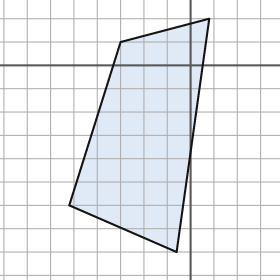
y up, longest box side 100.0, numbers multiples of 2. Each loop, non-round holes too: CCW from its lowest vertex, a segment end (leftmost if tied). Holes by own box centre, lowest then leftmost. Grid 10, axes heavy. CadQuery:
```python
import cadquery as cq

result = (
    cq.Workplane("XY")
    .moveTo(-6.0, -80.0)
    .lineTo(8.0, 20.0)
    .lineTo(-30.0, 10.0)
    .lineTo(-52.0, -60.0)
    .close()
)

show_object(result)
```